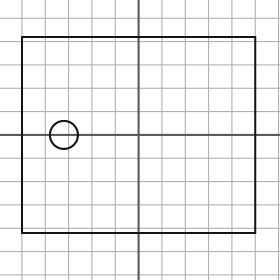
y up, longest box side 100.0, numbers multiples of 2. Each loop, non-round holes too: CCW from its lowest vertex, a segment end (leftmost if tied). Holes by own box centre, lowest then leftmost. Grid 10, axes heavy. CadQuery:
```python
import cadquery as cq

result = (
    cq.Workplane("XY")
    .moveTo(-50.0, -42.0)
    .lineTo(50.0, -42.0)
    .lineTo(50.0, 42.0)
    .lineTo(-50.0, 42.0)
    .close()
    .moveTo(-32.0, 0.0)
    .circle(6.0)
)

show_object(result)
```